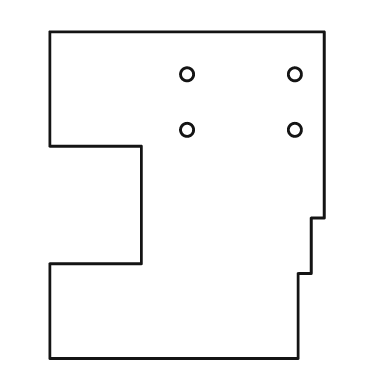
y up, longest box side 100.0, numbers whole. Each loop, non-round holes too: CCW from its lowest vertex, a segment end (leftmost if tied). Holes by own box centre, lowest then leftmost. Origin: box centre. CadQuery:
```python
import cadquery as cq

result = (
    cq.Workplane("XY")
    .moveTo(-42.0, -50.0)
    .lineTo(34.0, -50.0)
    .lineTo(34.0, -24.0)
    .lineTo(38.0, -24.0)
    .lineTo(38.0, -7.0)
    .lineTo(42.0, -7.0)
    .lineTo(42.0, 50.0)
    .lineTo(-42.0, 50.0)
    .lineTo(-42.0, 15.0)
    .lineTo(-14.0, 15.0)
    .lineTo(-14.0, -21.0)
    .lineTo(-42.0, -21.0)
    .close()
    .moveTo(0.0, 20.0)
    .circle(2.0)
    .moveTo(33.0, 20.0)
    .circle(2.0)
    .moveTo(0.0, 37.0)
    .circle(2.0)
    .moveTo(33.0, 37.0)
    .circle(2.0)
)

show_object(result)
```